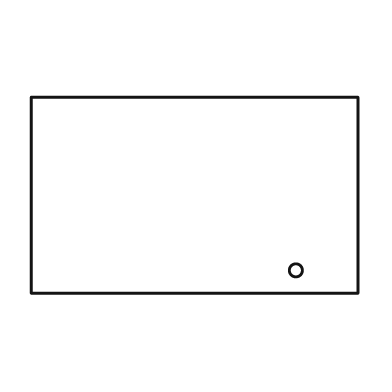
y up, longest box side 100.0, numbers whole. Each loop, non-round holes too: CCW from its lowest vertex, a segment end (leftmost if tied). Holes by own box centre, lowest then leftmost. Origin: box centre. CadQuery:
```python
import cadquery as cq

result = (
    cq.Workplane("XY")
    .moveTo(-50.0, -30.0)
    .lineTo(50.0, -30.0)
    .lineTo(50.0, 30.0)
    .lineTo(-50.0, 30.0)
    .close()
    .moveTo(31.0, -23.0)
    .circle(2.0)
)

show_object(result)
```